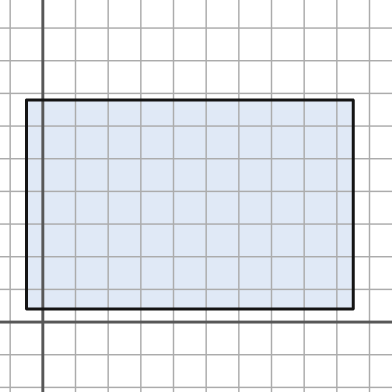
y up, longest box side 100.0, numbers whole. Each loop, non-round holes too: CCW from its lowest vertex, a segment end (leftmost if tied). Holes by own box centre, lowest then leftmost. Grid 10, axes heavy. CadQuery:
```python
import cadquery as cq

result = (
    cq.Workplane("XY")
    .moveTo(-5.0, 4.0)
    .lineTo(95.0, 4.0)
    .lineTo(95.0, 68.0)
    .lineTo(-5.0, 68.0)
    .close()
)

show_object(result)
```